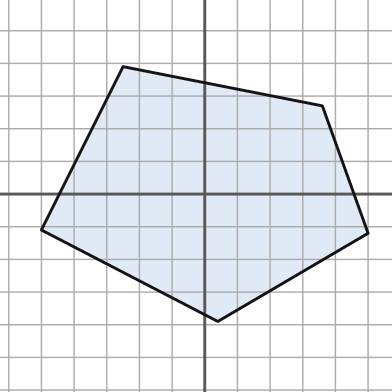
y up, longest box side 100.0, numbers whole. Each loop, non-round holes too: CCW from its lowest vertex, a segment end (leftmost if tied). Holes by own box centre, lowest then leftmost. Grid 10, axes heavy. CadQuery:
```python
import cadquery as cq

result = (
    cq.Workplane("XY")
    .moveTo(4.0, -39.0)
    .lineTo(50.0, -12.0)
    .lineTo(36.0, 27.0)
    .lineTo(-25.0, 39.0)
    .lineTo(-50.0, -11.0)
    .close()
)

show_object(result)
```